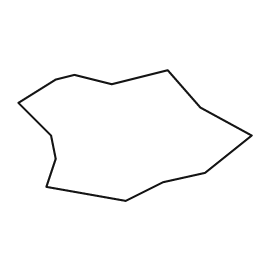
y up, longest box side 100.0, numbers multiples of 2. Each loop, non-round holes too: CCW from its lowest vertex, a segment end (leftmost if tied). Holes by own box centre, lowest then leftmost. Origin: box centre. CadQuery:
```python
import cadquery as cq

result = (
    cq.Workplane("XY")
    .moveTo(-4.0, -28.0)
    .lineTo(12.0, -20.0)
    .lineTo(30.0, -16.0)
    .lineTo(50.0, 0.0)
    .lineTo(28.0, 12.0)
    .lineTo(14.0, 28.0)
    .lineTo(-10.0, 22.0)
    .lineTo(-26.0, 26.0)
    .lineTo(-34.0, 24.0)
    .lineTo(-50.0, 14.0)
    .lineTo(-36.0, 0.0)
    .lineTo(-34.0, -10.0)
    .lineTo(-38.0, -22.0)
    .close()
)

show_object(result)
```